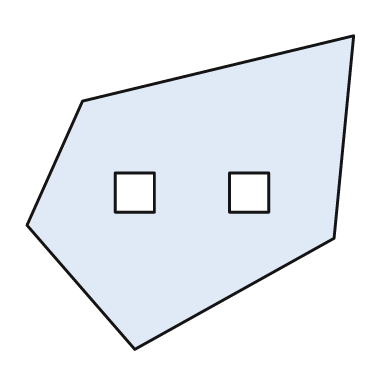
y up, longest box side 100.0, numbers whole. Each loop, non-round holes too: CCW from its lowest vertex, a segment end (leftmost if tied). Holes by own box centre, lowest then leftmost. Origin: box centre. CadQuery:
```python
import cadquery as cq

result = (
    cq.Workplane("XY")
    .moveTo(-17.0, -48.0)
    .lineTo(44.0, -14.0)
    .lineTo(50.0, 48.0)
    .lineTo(-33.0, 28.0)
    .lineTo(-50.0, -10.0)
    .close()
    .moveTo(-23.0, -6.0)
    .lineTo(-11.0, -6.0)
    .lineTo(-11.0, 6.0)
    .lineTo(-23.0, 6.0)
    .close()
    .moveTo(12.0, -6.0)
    .lineTo(24.0, -6.0)
    .lineTo(24.0, 6.0)
    .lineTo(12.0, 6.0)
    .close()
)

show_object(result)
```